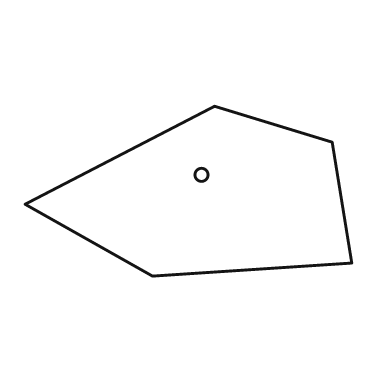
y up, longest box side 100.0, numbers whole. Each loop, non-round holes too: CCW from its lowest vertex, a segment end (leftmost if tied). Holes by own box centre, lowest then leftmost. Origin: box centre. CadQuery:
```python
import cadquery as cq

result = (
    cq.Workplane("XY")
    .moveTo(-11.0, -26.0)
    .lineTo(50.0, -22.0)
    .lineTo(44.0, 15.0)
    .lineTo(8.0, 26.0)
    .lineTo(-50.0, -4.0)
    .close()
    .moveTo(4.0, 5.0)
    .circle(2.0)
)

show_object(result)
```